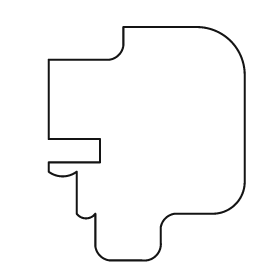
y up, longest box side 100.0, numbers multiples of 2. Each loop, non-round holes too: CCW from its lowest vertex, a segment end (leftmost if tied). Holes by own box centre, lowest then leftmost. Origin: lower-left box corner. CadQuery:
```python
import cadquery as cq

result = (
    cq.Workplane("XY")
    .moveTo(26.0, 0.0)
    .lineTo(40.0, 0.0)
    .threePointArc((46.0, 2.0), (48.0, 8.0))
    .lineTo(48.0, 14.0)
    .threePointArc((50.0, 18.0), (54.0, 20.0))
    .lineTo(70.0, 20.0)
    .threePointArc((80.0, 24.0), (84.0, 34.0))
    .lineTo(84.0, 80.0)
    .threePointArc((78.0, 94.0), (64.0, 100.0))
    .lineTo(32.0, 100.0)
    .lineTo(32.0, 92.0)
    .threePointArc((30.0, 88.0), (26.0, 86.0))
    .lineTo(0.0, 86.0)
    .lineTo(0.0, 52.0)
    .lineTo(22.0, 52.0)
    .lineTo(22.0, 42.0)
    .lineTo(0.0, 42.0)
    .lineTo(0.0, 38.0)
    .threePointArc((6.0, 36.0), (12.0, 38.0))
    .lineTo(12.0, 20.0)
    .threePointArc((16.0, 18.0), (20.0, 20.0))
    .lineTo(20.0, 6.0)
    .threePointArc((22.0, 2.0), (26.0, 0.0))
    .close()
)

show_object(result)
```